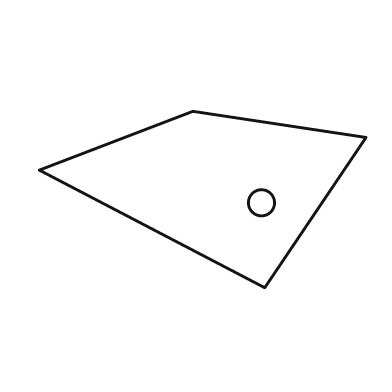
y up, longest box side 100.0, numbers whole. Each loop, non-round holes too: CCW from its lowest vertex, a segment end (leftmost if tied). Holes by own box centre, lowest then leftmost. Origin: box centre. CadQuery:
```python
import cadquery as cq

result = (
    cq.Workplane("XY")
    .moveTo(19.0, -27.0)
    .lineTo(50.0, 19.0)
    .lineTo(-3.0, 27.0)
    .lineTo(-50.0, 9.0)
    .close()
    .moveTo(18.0, -1.0)
    .circle(4.0)
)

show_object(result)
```